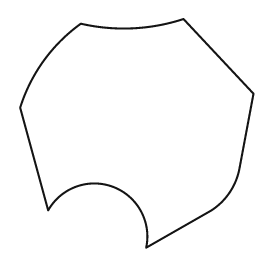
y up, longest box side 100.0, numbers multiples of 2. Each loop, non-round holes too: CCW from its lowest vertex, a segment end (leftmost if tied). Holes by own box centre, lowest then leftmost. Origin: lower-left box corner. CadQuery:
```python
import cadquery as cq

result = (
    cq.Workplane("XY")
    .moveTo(54.0, 0.0)
    .lineTo(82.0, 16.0)
    .threePointArc((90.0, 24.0), (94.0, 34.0))
    .lineTo(100.0, 66.0)
    .lineTo(70.0, 98.0)
    .threePointArc((48.0, 94.0), (26.0, 96.0))
    .threePointArc((10.0, 80.0), (0.0, 60.0))
    .lineTo(12.0, 16.0)
    .threePointArc((40.0, 26.0), (54.0, 0.0))
    .close()
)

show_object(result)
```